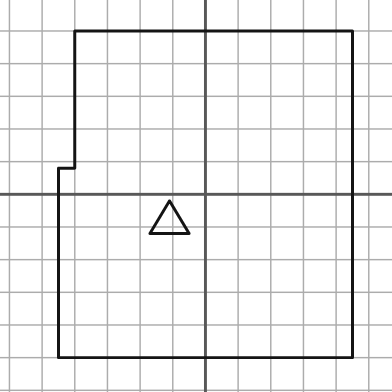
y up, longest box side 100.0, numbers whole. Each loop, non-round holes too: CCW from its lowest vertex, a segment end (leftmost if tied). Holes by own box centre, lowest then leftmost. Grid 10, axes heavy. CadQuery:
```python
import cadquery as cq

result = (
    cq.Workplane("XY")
    .moveTo(-45.0, -50.0)
    .lineTo(45.0, -50.0)
    .lineTo(45.0, 50.0)
    .lineTo(-40.0, 50.0)
    .lineTo(-40.0, 8.0)
    .lineTo(-45.0, 8.0)
    .close()
    .moveTo(-17.0, -12.0)
    .lineTo(-5.0, -12.0)
    .lineTo(-11.0, -2.0)
    .close()
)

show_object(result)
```